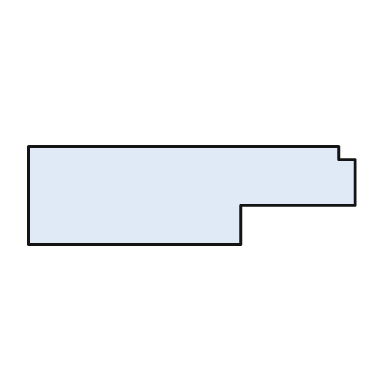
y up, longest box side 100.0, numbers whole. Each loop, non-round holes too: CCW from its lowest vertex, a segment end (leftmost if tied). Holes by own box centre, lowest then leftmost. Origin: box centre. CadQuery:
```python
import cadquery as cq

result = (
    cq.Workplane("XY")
    .moveTo(-50.0, -15.0)
    .lineTo(15.0, -15.0)
    .lineTo(15.0, -3.0)
    .lineTo(50.0, -3.0)
    .lineTo(50.0, 11.0)
    .lineTo(45.0, 11.0)
    .lineTo(45.0, 15.0)
    .lineTo(-50.0, 15.0)
    .close()
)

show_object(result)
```